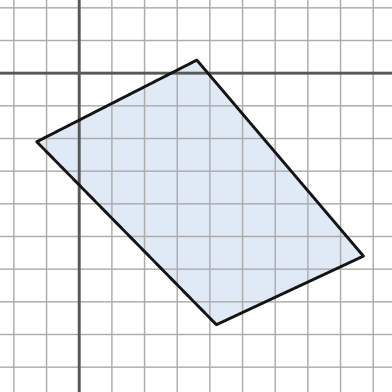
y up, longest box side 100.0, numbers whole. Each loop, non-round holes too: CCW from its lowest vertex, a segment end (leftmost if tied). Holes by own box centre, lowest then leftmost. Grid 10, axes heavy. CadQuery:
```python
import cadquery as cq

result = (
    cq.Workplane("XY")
    .moveTo(42.0, -77.0)
    .lineTo(87.0, -56.0)
    .lineTo(36.0, 4.0)
    .lineTo(-13.0, -21.0)
    .close()
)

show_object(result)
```